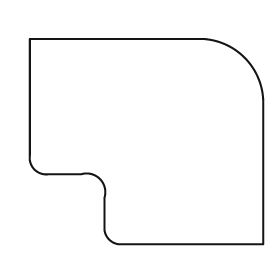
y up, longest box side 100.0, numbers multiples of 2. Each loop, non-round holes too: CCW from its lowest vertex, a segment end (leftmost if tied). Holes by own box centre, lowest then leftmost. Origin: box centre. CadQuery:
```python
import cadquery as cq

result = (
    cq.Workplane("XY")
    .moveTo(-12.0, -44.0)
    .lineTo(50.0, -44.0)
    .lineTo(50.0, 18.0)
    .threePointArc((42.0, 36.0), (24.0, 44.0))
    .lineTo(-50.0, 44.0)
    .lineTo(-50.0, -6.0)
    .threePointArc((-48.0, -12.0), (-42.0, -14.0))
    .lineTo(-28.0, -14.0)
    .threePointArc((-20.0, -16.0), (-18.0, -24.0))
    .lineTo(-18.0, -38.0)
    .threePointArc((-16.0, -42.0), (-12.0, -44.0))
    .close()
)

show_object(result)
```